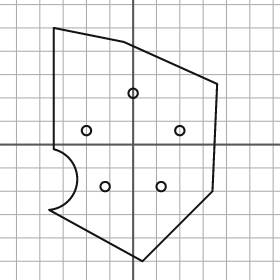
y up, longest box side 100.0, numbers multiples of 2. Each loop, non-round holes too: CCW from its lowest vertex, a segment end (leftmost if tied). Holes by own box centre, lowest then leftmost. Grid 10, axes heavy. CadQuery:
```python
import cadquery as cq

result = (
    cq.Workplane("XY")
    .moveTo(4.0, -50.0)
    .lineTo(34.0, -20.0)
    .lineTo(36.0, 26.0)
    .lineTo(-4.0, 44.0)
    .lineTo(-34.0, 50.0)
    .lineTo(-34.0, -2.0)
    .threePointArc((-24.0, -16.0), (-36.0, -28.0))
    .close()
    .moveTo(-12.0, -18.0)
    .circle(2.0)
    .moveTo(12.0, -18.0)
    .circle(2.0)
    .moveTo(-20.0, 6.0)
    .circle(2.0)
    .moveTo(20.0, 6.0)
    .circle(2.0)
    .moveTo(0.0, 22.0)
    .circle(2.0)
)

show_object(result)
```